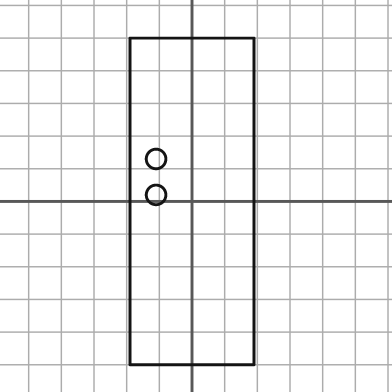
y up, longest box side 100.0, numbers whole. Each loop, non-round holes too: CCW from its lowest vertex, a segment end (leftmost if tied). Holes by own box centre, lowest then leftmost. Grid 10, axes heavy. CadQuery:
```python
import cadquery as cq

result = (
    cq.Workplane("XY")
    .moveTo(-19.0, -50.0)
    .lineTo(19.0, -50.0)
    .lineTo(19.0, 50.0)
    .lineTo(-19.0, 50.0)
    .close()
    .moveTo(-11.0, 2.0)
    .circle(3.0)
    .moveTo(-11.0, 13.0)
    .circle(3.0)
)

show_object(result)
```